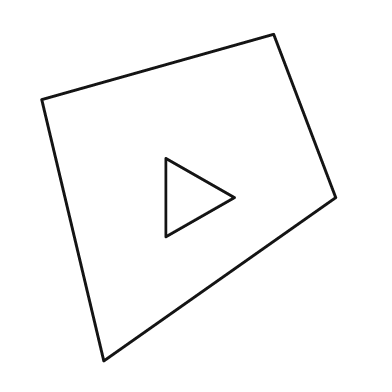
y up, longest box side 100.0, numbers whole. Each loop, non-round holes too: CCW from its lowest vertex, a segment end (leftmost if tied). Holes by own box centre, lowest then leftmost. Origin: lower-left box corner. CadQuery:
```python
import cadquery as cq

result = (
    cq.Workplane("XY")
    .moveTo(19.0, 0.0)
    .lineTo(90.0, 50.0)
    .lineTo(71.0, 100.0)
    .lineTo(0.0, 80.0)
    .close()
    .moveTo(38.0, 38.0)
    .lineTo(59.0, 50.0)
    .lineTo(38.0, 62.0)
    .close()
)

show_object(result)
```